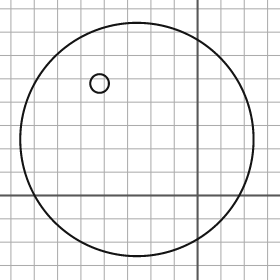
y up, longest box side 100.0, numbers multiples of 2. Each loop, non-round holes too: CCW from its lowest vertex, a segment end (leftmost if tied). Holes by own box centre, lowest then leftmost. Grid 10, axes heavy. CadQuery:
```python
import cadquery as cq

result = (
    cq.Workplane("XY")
    .moveTo(-26.0, 24.0)
    .circle(50.0)
    .moveTo(-42.0, 48.0)
    .circle(4.0)
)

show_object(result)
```